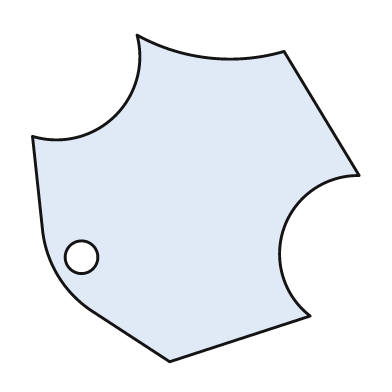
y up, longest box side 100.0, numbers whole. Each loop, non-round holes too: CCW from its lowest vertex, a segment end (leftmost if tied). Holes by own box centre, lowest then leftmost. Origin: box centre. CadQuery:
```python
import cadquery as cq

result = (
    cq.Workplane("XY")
    .moveTo(-8.0, -50.0)
    .lineTo(35.0, -36.0)
    .threePointArc((27.0, -9.0), (50.0, 7.0))
    .lineTo(27.0, 45.0)
    .threePointArc((4.0, 43.0), (-18.0, 50.0))
    .threePointArc((-25.0, 25.0), (-50.0, 19.0))
    .lineTo(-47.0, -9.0)
    .threePointArc((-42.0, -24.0), (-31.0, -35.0))
    .close()
    .moveTo(-35.0, -18.0)
    .circle(5.0)
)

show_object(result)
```